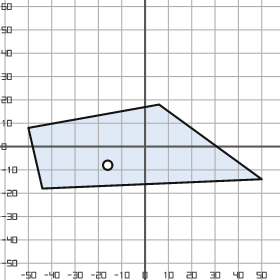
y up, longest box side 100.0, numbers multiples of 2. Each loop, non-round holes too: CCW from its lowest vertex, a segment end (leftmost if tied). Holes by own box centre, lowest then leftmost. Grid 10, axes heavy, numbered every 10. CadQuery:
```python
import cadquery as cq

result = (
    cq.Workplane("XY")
    .moveTo(-44.0, -18.0)
    .lineTo(50.0, -14.0)
    .lineTo(6.0, 18.0)
    .lineTo(-50.0, 8.0)
    .close()
    .moveTo(-16.0, -8.0)
    .circle(2.0)
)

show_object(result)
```